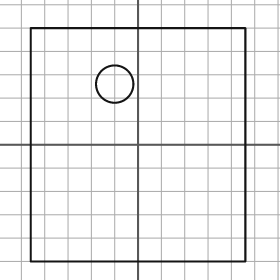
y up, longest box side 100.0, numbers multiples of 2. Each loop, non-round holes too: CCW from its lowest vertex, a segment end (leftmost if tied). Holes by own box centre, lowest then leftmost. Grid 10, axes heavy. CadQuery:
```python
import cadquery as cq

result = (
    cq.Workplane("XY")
    .moveTo(-46.0, -50.0)
    .lineTo(46.0, -50.0)
    .lineTo(46.0, 50.0)
    .lineTo(-46.0, 50.0)
    .close()
    .moveTo(-10.0, 26.0)
    .circle(8.0)
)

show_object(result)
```